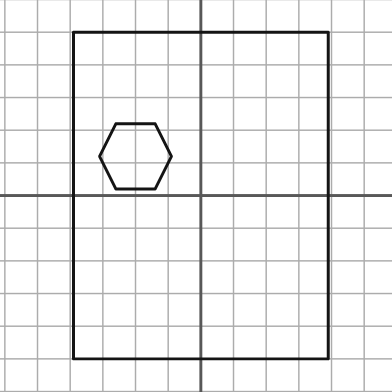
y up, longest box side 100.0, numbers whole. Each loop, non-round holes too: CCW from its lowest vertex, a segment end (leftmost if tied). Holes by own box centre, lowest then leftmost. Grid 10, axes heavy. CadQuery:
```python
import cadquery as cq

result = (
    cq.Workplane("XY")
    .moveTo(-39.0, -50.0)
    .lineTo(39.0, -50.0)
    .lineTo(39.0, 50.0)
    .lineTo(-39.0, 50.0)
    .close()
    .moveTo(-26.0, 2.0)
    .lineTo(-14.0, 2.0)
    .lineTo(-9.0, 12.0)
    .lineTo(-14.0, 22.0)
    .lineTo(-26.0, 22.0)
    .lineTo(-31.0, 12.0)
    .close()
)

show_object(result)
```